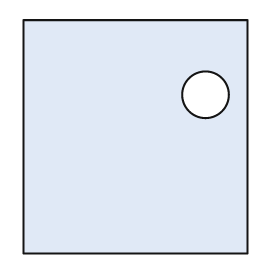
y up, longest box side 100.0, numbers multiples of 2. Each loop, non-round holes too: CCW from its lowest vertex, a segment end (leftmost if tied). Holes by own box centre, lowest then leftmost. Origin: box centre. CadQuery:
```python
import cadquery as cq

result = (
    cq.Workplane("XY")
    .moveTo(-48.0, -50.0)
    .lineTo(48.0, -50.0)
    .lineTo(48.0, 50.0)
    .lineTo(-48.0, 50.0)
    .close()
    .moveTo(30.0, 18.0)
    .circle(10.0)
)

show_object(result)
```